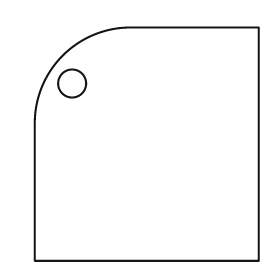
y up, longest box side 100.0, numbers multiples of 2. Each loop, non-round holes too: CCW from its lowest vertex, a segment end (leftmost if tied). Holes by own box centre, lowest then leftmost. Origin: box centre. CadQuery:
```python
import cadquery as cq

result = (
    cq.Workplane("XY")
    .moveTo(-48.0, -50.0)
    .lineTo(48.0, -50.0)
    .lineTo(48.0, 50.0)
    .lineTo(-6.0, 50.0)
    .threePointArc((-36.0, 38.0), (-48.0, 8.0))
    .close()
    .moveTo(-32.0, 26.0)
    .circle(6.0)
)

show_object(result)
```